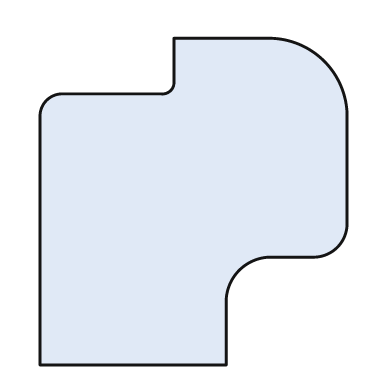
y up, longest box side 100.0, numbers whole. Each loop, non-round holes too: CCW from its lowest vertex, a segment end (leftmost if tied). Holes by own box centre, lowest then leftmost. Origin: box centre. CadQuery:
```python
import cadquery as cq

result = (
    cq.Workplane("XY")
    .moveTo(-47.0, -50.0)
    .lineTo(10.0, -50.0)
    .lineTo(10.0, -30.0)
    .threePointArc((14.0, -21.0), (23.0, -17.0))
    .lineTo(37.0, -17.0)
    .threePointArc((44.0, -14.0), (47.0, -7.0))
    .lineTo(47.0, 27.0)
    .threePointArc((40.0, 43.0), (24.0, 50.0))
    .lineTo(-6.0, 50.0)
    .lineTo(-6.0, 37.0)
    .threePointArc((-7.0, 34.0), (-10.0, 33.0))
    .lineTo(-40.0, 33.0)
    .threePointArc((-45.0, 31.0), (-47.0, 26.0))
    .close()
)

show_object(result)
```